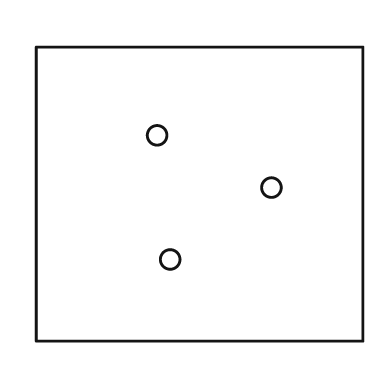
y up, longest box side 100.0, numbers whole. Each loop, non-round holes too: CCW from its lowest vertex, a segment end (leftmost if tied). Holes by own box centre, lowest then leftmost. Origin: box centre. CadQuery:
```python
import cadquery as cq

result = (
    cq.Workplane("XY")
    .moveTo(-50.0, -45.0)
    .lineTo(50.0, -45.0)
    .lineTo(50.0, 45.0)
    .lineTo(-50.0, 45.0)
    .close()
    .moveTo(-9.0, -20.0)
    .circle(3.0)
    .moveTo(22.0, 2.0)
    .circle(3.0)
    .moveTo(-13.0, 18.0)
    .circle(3.0)
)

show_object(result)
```